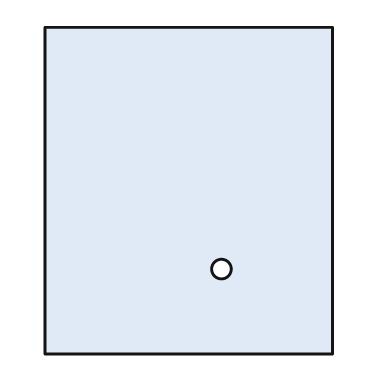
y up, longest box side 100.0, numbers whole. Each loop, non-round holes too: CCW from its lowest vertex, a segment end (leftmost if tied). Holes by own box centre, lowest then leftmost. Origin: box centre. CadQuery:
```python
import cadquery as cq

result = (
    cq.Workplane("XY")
    .moveTo(-44.0, -50.0)
    .lineTo(44.0, -50.0)
    .lineTo(44.0, 50.0)
    .lineTo(-44.0, 50.0)
    .close()
    .moveTo(10.0, -24.0)
    .circle(3.0)
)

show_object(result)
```